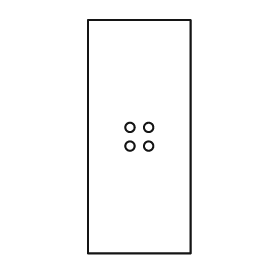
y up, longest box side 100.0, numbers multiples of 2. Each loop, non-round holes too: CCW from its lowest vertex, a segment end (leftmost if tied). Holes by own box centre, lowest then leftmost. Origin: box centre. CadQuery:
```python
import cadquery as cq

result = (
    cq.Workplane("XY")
    .moveTo(-22.0, -50.0)
    .lineTo(22.0, -50.0)
    .lineTo(22.0, 50.0)
    .lineTo(-22.0, 50.0)
    .close()
    .moveTo(-4.0, -4.0)
    .circle(2.0)
    .moveTo(4.0, -4.0)
    .circle(2.0)
    .moveTo(-4.0, 4.0)
    .circle(2.0)
    .moveTo(4.0, 4.0)
    .circle(2.0)
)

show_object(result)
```